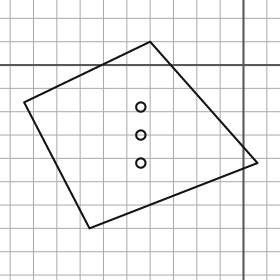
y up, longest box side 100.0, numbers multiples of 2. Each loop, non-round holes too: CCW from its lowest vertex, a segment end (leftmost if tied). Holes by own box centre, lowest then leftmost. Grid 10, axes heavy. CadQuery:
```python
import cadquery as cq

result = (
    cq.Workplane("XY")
    .moveTo(-66.0, -70.0)
    .lineTo(6.0, -42.0)
    .lineTo(-40.0, 10.0)
    .lineTo(-94.0, -16.0)
    .close()
    .moveTo(-44.0, -42.0)
    .circle(2.0)
    .moveTo(-44.0, -30.0)
    .circle(2.0)
    .moveTo(-44.0, -18.0)
    .circle(2.0)
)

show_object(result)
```